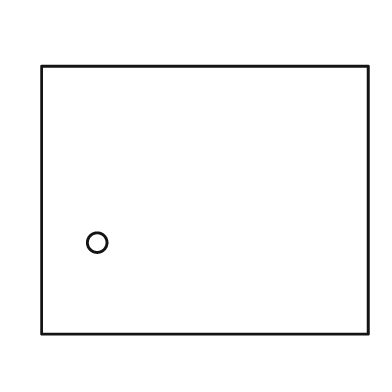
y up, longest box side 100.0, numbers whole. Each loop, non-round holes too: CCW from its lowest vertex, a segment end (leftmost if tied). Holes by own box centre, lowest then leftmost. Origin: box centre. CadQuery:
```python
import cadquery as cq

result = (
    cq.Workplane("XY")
    .moveTo(-50.0, -41.0)
    .lineTo(50.0, -41.0)
    .lineTo(50.0, 41.0)
    .lineTo(-50.0, 41.0)
    .close()
    .moveTo(-33.0, -13.0)
    .circle(3.0)
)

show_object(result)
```